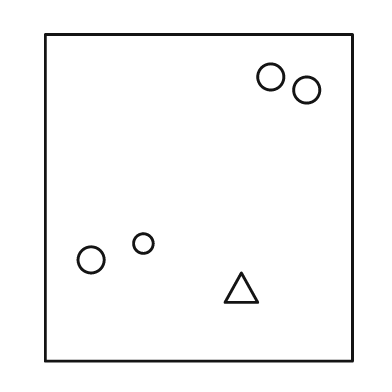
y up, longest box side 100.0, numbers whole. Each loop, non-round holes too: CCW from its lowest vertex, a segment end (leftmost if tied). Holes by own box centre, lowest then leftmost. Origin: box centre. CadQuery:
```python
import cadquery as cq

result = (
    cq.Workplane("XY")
    .moveTo(-47.0, -50.0)
    .lineTo(47.0, -50.0)
    .lineTo(47.0, 50.0)
    .lineTo(-47.0, 50.0)
    .close()
    .moveTo(8.0, -32.0)
    .lineTo(18.0, -32.0)
    .lineTo(13.0, -23.0)
    .close()
    .moveTo(-33.0, -19.0)
    .circle(4.0)
    .moveTo(-17.0, -14.0)
    .circle(3.0)
    .moveTo(33.0, 33.0)
    .circle(4.0)
    .moveTo(22.0, 37.0)
    .circle(4.0)
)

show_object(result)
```